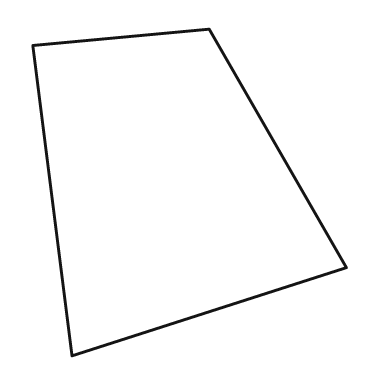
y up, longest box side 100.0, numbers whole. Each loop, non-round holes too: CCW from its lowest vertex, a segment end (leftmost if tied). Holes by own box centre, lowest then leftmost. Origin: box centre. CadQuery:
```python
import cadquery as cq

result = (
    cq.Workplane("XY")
    .moveTo(-36.0, -50.0)
    .lineTo(48.0, -23.0)
    .lineTo(6.0, 50.0)
    .lineTo(-48.0, 45.0)
    .close()
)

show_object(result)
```